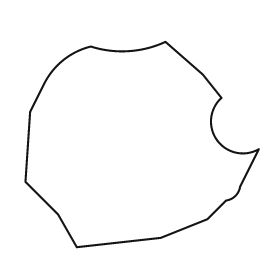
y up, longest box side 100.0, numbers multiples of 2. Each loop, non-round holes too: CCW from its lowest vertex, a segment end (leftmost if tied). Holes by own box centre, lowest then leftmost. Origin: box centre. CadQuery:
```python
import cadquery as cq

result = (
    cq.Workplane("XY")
    .moveTo(-28.0, -44.0)
    .lineTo(8.0, -40.0)
    .lineTo(28.0, -32.0)
    .lineTo(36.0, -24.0)
    .threePointArc((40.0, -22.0), (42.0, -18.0))
    .lineTo(50.0, -2.0)
    .threePointArc((32.0, 2.0), (34.0, 20.0))
    .lineTo(26.0, 30.0)
    .lineTo(10.0, 44.0)
    .threePointArc((-6.0, 40.0), (-22.0, 42.0))
    .threePointArc((-34.0, 36.0), (-42.0, 26.0))
    .lineTo(-48.0, 14.0)
    .lineTo(-50.0, -16.0)
    .lineTo(-36.0, -30.0)
    .close()
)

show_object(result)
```